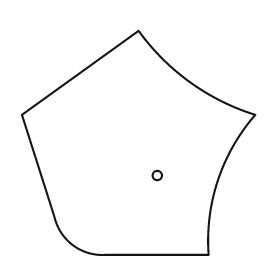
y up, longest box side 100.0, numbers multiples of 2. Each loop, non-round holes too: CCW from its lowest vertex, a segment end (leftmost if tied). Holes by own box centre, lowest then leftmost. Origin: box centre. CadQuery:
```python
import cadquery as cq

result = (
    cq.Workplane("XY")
    .moveTo(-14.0, -48.0)
    .lineTo(30.0, -48.0)
    .threePointArc((34.0, -16.0), (50.0, 12.0))
    .threePointArc((22.0, 26.0), (0.0, 48.0))
    .lineTo(-50.0, 12.0)
    .lineTo(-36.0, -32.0)
    .threePointArc((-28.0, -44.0), (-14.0, -48.0))
    .close()
    .moveTo(8.0, -14.0)
    .circle(2.0)
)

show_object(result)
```